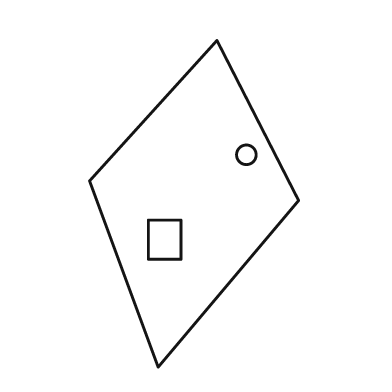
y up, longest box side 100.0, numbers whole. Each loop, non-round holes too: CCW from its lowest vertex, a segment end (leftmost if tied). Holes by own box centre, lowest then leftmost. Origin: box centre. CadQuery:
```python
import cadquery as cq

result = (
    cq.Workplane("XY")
    .moveTo(-11.0, -50.0)
    .lineTo(32.0, 1.0)
    .lineTo(7.0, 50.0)
    .lineTo(-32.0, 7.0)
    .close()
    .moveTo(-14.0, -17.0)
    .lineTo(-4.0, -17.0)
    .lineTo(-4.0, -5.0)
    .lineTo(-14.0, -5.0)
    .close()
    .moveTo(16.0, 15.0)
    .circle(3.0)
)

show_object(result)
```